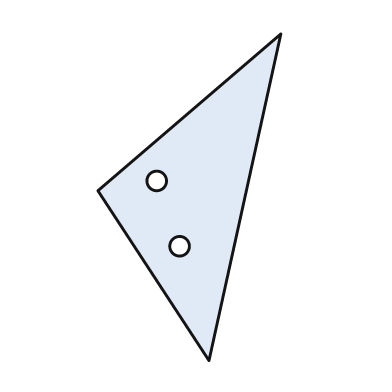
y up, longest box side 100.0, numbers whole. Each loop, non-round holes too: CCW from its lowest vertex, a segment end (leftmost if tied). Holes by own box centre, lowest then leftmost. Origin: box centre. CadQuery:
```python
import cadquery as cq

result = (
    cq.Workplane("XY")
    .moveTo(6.0, -50.0)
    .lineTo(28.0, 50.0)
    .lineTo(-28.0, 2.0)
    .close()
    .moveTo(-3.0, -15.0)
    .circle(3.0)
    .moveTo(-10.0, 5.0)
    .circle(3.0)
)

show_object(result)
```